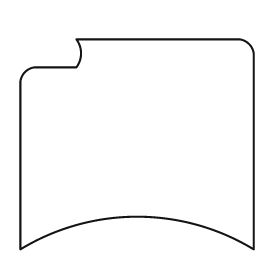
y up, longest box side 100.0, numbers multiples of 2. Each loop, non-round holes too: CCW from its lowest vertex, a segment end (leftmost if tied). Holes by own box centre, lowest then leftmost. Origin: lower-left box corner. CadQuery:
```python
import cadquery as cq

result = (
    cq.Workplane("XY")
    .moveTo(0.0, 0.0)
    .threePointArc((50.0, 14.0), (100.0, 0.0))
    .lineTo(100.0, 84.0)
    .threePointArc((98.0, 88.0), (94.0, 90.0))
    .lineTo(24.0, 90.0)
    .threePointArc((26.0, 84.0), (24.0, 78.0))
    .lineTo(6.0, 78.0)
    .threePointArc((2.0, 76.0), (0.0, 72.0))
    .close()
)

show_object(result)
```